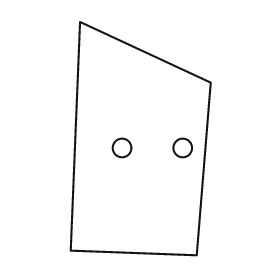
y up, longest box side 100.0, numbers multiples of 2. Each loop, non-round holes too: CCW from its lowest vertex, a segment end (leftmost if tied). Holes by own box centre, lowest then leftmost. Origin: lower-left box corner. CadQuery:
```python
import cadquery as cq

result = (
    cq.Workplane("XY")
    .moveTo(54.0, 0.0)
    .lineTo(60.0, 74.0)
    .lineTo(4.0, 100.0)
    .lineTo(0.0, 2.0)
    .close()
    .moveTo(22.0, 46.0)
    .circle(4.0)
    .moveTo(48.0, 46.0)
    .circle(4.0)
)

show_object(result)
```